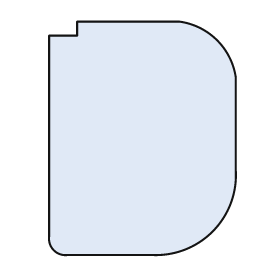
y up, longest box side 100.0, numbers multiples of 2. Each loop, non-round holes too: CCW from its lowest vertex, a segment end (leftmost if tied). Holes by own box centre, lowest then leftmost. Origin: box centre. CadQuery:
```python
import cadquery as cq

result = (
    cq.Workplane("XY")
    .moveTo(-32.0, -50.0)
    .lineTo(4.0, -50.0)
    .threePointArc((30.0, -40.0), (40.0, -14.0))
    .lineTo(40.0, 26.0)
    .threePointArc((32.0, 42.0), (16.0, 50.0))
    .lineTo(-28.0, 50.0)
    .lineTo(-28.0, 44.0)
    .lineTo(-40.0, 44.0)
    .lineTo(-40.0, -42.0)
    .threePointArc((-38.0, -48.0), (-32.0, -50.0))
    .close()
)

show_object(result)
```